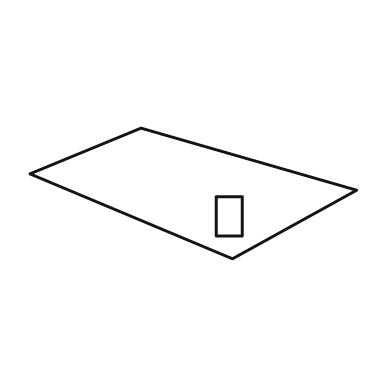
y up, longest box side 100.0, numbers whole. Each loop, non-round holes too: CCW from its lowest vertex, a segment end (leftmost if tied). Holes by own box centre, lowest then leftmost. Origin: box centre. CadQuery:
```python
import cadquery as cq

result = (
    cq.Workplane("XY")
    .moveTo(12.0, -20.0)
    .lineTo(50.0, 1.0)
    .lineTo(-16.0, 20.0)
    .lineTo(-50.0, 6.0)
    .close()
    .moveTo(7.0, -13.0)
    .lineTo(15.0, -13.0)
    .lineTo(15.0, -1.0)
    .lineTo(7.0, -1.0)
    .close()
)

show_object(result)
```